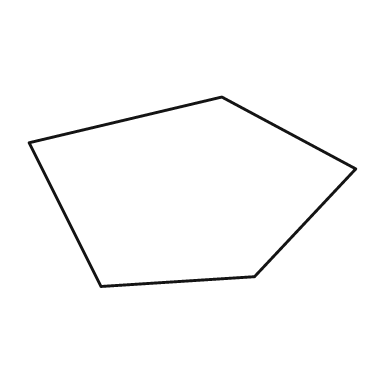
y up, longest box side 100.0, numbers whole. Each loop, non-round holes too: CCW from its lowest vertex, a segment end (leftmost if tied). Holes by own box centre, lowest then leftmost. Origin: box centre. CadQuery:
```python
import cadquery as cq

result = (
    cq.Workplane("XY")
    .moveTo(-28.0, -29.0)
    .lineTo(19.0, -26.0)
    .lineTo(50.0, 7.0)
    .lineTo(9.0, 29.0)
    .lineTo(-50.0, 15.0)
    .close()
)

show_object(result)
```